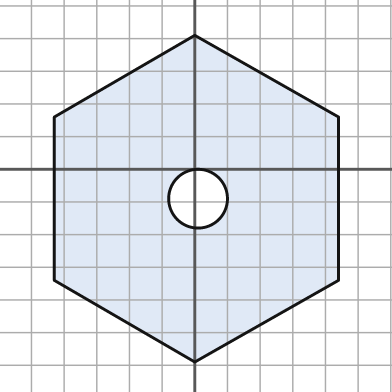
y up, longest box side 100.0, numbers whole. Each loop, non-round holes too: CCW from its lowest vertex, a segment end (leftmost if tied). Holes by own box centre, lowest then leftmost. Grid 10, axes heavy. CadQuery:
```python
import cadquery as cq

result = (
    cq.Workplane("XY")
    .moveTo(0.0, -59.0)
    .lineTo(44.0, -34.0)
    .lineTo(44.0, 16.0)
    .lineTo(0.0, 41.0)
    .lineTo(-43.0, 16.0)
    .lineTo(-43.0, -34.0)
    .close()
    .moveTo(1.0, -9.0)
    .circle(9.0)
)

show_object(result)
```